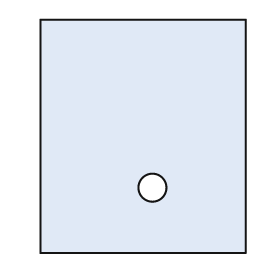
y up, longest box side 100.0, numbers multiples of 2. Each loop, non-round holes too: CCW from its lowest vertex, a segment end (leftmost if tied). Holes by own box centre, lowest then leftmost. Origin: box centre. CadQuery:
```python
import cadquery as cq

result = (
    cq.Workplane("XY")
    .moveTo(-44.0, -50.0)
    .lineTo(44.0, -50.0)
    .lineTo(44.0, 50.0)
    .lineTo(-44.0, 50.0)
    .close()
    .moveTo(4.0, -22.0)
    .circle(6.0)
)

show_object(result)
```